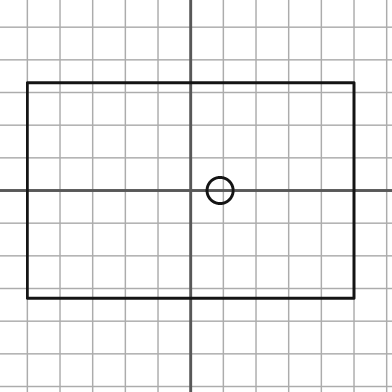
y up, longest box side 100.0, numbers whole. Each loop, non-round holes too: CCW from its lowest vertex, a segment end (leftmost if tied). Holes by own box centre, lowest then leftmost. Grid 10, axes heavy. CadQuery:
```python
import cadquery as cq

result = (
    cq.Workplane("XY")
    .moveTo(-50.0, -33.0)
    .lineTo(50.0, -33.0)
    .lineTo(50.0, 33.0)
    .lineTo(-50.0, 33.0)
    .close()
    .moveTo(9.0, 0.0)
    .circle(4.0)
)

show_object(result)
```